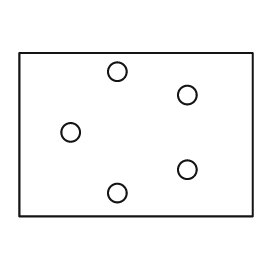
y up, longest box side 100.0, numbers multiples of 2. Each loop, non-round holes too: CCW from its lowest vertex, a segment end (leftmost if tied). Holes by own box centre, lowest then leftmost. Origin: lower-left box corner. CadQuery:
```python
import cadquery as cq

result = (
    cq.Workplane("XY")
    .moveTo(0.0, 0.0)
    .lineTo(100.0, 0.0)
    .lineTo(100.0, 70.0)
    .lineTo(0.0, 70.0)
    .close()
    .moveTo(42.0, 10.0)
    .circle(4.0)
    .moveTo(72.0, 20.0)
    .circle(4.0)
    .moveTo(22.0, 36.0)
    .circle(4.0)
    .moveTo(72.0, 52.0)
    .circle(4.0)
    .moveTo(42.0, 62.0)
    .circle(4.0)
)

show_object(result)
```